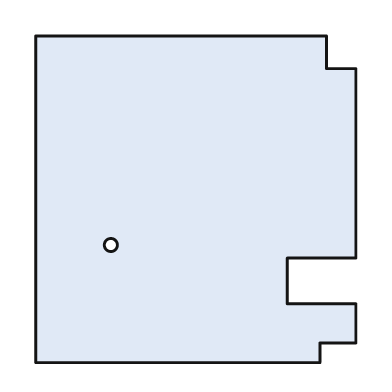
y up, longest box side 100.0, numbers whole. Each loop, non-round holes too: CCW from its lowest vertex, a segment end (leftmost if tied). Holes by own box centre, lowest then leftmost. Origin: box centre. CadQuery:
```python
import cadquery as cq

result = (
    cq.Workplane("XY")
    .moveTo(-49.0, -50.0)
    .lineTo(38.0, -50.0)
    .lineTo(38.0, -44.0)
    .lineTo(49.0, -44.0)
    .lineTo(49.0, -32.0)
    .lineTo(28.0, -32.0)
    .lineTo(28.0, -18.0)
    .lineTo(49.0, -18.0)
    .lineTo(49.0, 40.0)
    .lineTo(40.0, 40.0)
    .lineTo(40.0, 50.0)
    .lineTo(-49.0, 50.0)
    .close()
    .moveTo(-26.0, -14.0)
    .circle(2.0)
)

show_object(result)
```